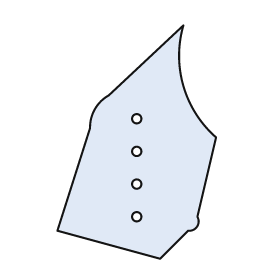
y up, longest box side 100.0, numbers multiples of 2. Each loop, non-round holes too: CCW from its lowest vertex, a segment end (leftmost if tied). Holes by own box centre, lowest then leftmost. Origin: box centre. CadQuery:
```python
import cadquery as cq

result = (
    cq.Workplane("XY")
    .moveTo(10.0, -50.0)
    .lineTo(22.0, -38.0)
    .threePointArc((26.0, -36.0), (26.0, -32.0))
    .lineTo(34.0, 2.0)
    .threePointArc((20.0, 24.0), (20.0, 50.0))
    .lineTo(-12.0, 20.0)
    .threePointArc((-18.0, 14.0), (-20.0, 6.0))
    .lineTo(-34.0, -38.0)
    .close()
    .moveTo(0.0, -32.0)
    .circle(2.0)
    .moveTo(0.0, -18.0)
    .circle(2.0)
    .moveTo(0.0, -4.0)
    .circle(2.0)
    .moveTo(0.0, 10.0)
    .circle(2.0)
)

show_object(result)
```